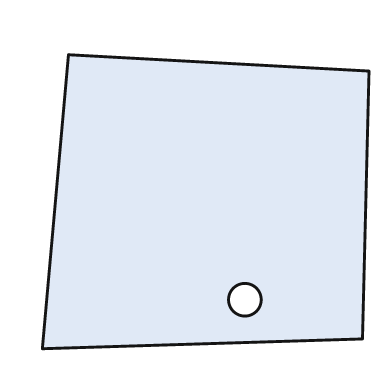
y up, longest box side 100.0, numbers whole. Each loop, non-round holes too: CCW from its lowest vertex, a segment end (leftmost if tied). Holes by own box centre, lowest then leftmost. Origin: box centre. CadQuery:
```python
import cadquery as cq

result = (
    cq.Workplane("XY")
    .moveTo(-50.0, -45.0)
    .lineTo(48.0, -42.0)
    .lineTo(50.0, 40.0)
    .lineTo(-42.0, 45.0)
    .close()
    .moveTo(12.0, -30.0)
    .circle(5.0)
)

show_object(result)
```